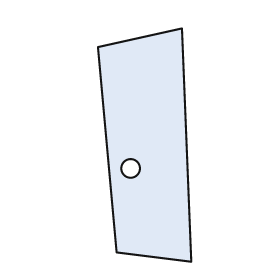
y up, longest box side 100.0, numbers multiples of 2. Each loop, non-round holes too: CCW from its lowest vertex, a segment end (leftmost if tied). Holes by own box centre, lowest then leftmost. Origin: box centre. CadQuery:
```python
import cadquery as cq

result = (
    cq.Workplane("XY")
    .moveTo(20.0, -50.0)
    .lineTo(16.0, 50.0)
    .lineTo(-20.0, 42.0)
    .lineTo(-12.0, -46.0)
    .close()
    .moveTo(-6.0, -10.0)
    .circle(4.0)
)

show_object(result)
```